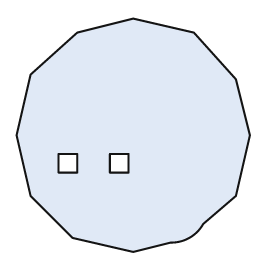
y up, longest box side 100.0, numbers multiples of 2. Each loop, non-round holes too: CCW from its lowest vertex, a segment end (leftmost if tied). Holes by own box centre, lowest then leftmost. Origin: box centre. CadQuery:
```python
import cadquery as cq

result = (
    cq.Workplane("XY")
    .moveTo(0.0, -50.0)
    .lineTo(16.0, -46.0)
    .threePointArc((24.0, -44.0), (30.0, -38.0))
    .lineTo(44.0, -26.0)
    .lineTo(50.0, 0.0)
    .lineTo(44.0, 24.0)
    .lineTo(26.0, 44.0)
    .lineTo(0.0, 50.0)
    .lineTo(-24.0, 44.0)
    .lineTo(-44.0, 26.0)
    .lineTo(-50.0, 0.0)
    .lineTo(-44.0, -26.0)
    .lineTo(-26.0, -44.0)
    .close()
    .moveTo(-32.0, -16.0)
    .lineTo(-24.0, -16.0)
    .lineTo(-24.0, -8.0)
    .lineTo(-32.0, -8.0)
    .close()
    .moveTo(-10.0, -16.0)
    .lineTo(-2.0, -16.0)
    .lineTo(-2.0, -8.0)
    .lineTo(-10.0, -8.0)
    .close()
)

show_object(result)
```